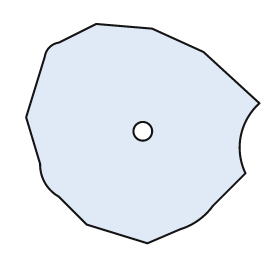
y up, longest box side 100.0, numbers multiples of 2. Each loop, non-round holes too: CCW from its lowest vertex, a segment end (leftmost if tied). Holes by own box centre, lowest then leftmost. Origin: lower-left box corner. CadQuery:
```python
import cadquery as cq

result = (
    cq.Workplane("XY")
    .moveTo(52.0, 0.0)
    .lineTo(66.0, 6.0)
    .threePointArc((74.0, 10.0), (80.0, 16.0))
    .lineTo(94.0, 30.0)
    .threePointArc((92.0, 46.0), (100.0, 60.0))
    .lineTo(76.0, 82.0)
    .lineTo(54.0, 92.0)
    .lineTo(30.0, 94.0)
    .lineTo(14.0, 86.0)
    .threePointArc((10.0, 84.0), (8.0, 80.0))
    .lineTo(0.0, 54.0)
    .lineTo(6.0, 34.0)
    .threePointArc((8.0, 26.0), (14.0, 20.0))
    .lineTo(26.0, 8.0)
    .close()
    .moveTo(50.0, 48.0)
    .circle(4.0)
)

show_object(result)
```